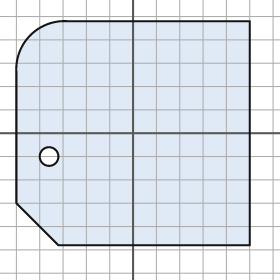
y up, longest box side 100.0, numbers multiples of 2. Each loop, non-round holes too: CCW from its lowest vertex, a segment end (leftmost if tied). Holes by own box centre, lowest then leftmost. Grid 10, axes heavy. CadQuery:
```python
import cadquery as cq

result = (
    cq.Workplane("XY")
    .moveTo(-32.0, -48.0)
    .lineTo(50.0, -48.0)
    .lineTo(50.0, 48.0)
    .lineTo(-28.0, 48.0)
    .threePointArc((-44.0, 42.0), (-50.0, 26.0))
    .lineTo(-50.0, -30.0)
    .close()
    .moveTo(-36.0, -10.0)
    .circle(4.0)
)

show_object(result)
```